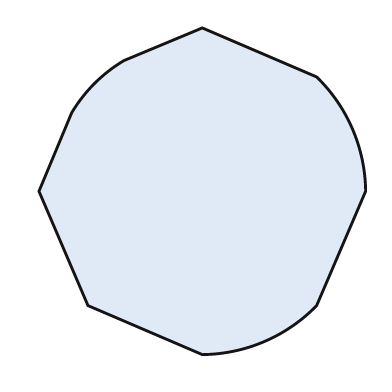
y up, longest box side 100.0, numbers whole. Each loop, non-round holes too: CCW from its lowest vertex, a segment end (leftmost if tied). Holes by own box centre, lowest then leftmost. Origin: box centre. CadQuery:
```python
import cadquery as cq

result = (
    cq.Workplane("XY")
    .moveTo(0.0, -50.0)
    .threePointArc((19.0, -46.0), (35.0, -35.0))
    .lineTo(50.0, 0.0)
    .threePointArc((46.0, 19.0), (35.0, 35.0))
    .lineTo(0.0, 50.0)
    .lineTo(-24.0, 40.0)
    .threePointArc((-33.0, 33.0), (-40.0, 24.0))
    .lineTo(-50.0, 0.0)
    .lineTo(-35.0, -35.0)
    .close()
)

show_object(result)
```